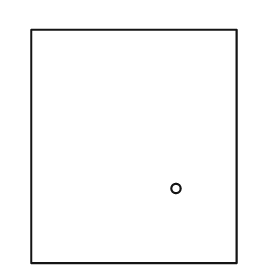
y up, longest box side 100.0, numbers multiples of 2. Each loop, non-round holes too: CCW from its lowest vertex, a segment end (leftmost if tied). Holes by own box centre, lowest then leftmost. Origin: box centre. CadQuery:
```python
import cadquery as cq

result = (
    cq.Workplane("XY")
    .moveTo(-44.0, -50.0)
    .lineTo(44.0, -50.0)
    .lineTo(44.0, 50.0)
    .lineTo(-44.0, 50.0)
    .close()
    .moveTo(18.0, -18.0)
    .circle(2.0)
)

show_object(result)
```